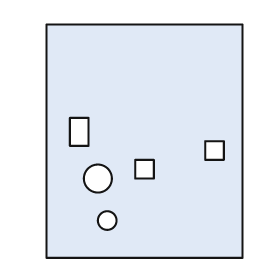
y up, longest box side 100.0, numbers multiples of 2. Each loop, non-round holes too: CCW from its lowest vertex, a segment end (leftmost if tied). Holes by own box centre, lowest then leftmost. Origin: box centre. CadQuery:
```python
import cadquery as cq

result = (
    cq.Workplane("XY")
    .moveTo(-42.0, -50.0)
    .lineTo(42.0, -50.0)
    .lineTo(42.0, 50.0)
    .lineTo(-42.0, 50.0)
    .close()
    .moveTo(-16.0, -34.0)
    .circle(4.0)
    .moveTo(-20.0, -16.0)
    .circle(6.0)
    .moveTo(-4.0, -16.0)
    .lineTo(4.0, -16.0)
    .lineTo(4.0, -8.0)
    .lineTo(-4.0, -8.0)
    .close()
    .moveTo(26.0, -8.0)
    .lineTo(34.0, -8.0)
    .lineTo(34.0, 0.0)
    .lineTo(26.0, 0.0)
    .close()
    .moveTo(-32.0, -2.0)
    .lineTo(-24.0, -2.0)
    .lineTo(-24.0, 10.0)
    .lineTo(-32.0, 10.0)
    .close()
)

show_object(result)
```